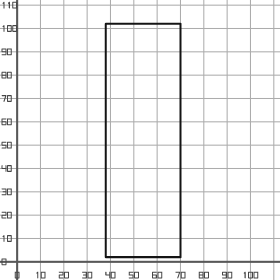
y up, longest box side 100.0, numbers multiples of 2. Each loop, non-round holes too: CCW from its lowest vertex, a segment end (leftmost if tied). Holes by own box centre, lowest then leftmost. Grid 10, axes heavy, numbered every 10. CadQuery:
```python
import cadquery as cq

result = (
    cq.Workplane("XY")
    .moveTo(38.0, 2.0)
    .lineTo(70.0, 2.0)
    .lineTo(70.0, 102.0)
    .lineTo(38.0, 102.0)
    .close()
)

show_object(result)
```